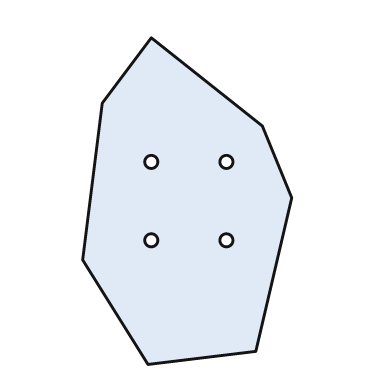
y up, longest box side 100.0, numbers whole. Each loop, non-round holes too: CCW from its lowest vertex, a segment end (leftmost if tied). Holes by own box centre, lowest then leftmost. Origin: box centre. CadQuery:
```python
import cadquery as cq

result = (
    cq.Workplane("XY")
    .moveTo(-12.0, -50.0)
    .lineTo(21.0, -46.0)
    .lineTo(32.0, 1.0)
    .lineTo(23.0, 23.0)
    .lineTo(-11.0, 50.0)
    .lineTo(-26.0, 30.0)
    .lineTo(-32.0, -18.0)
    .close()
    .moveTo(-11.0, -12.0)
    .circle(2.0)
    .moveTo(12.0, -12.0)
    .circle(2.0)
    .moveTo(-11.0, 12.0)
    .circle(2.0)
    .moveTo(12.0, 12.0)
    .circle(2.0)
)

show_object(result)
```